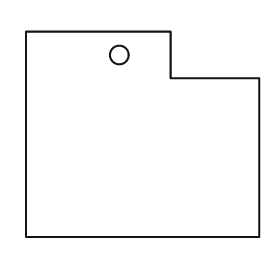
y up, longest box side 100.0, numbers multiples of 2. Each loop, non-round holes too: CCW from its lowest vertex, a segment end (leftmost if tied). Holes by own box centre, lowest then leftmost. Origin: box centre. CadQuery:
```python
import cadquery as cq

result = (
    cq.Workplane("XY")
    .moveTo(-50.0, -44.0)
    .lineTo(50.0, -44.0)
    .lineTo(50.0, 24.0)
    .lineTo(12.0, 24.0)
    .lineTo(12.0, 44.0)
    .lineTo(-50.0, 44.0)
    .close()
    .moveTo(-10.0, 34.0)
    .circle(4.0)
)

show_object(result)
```